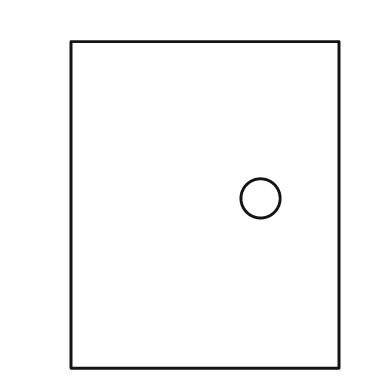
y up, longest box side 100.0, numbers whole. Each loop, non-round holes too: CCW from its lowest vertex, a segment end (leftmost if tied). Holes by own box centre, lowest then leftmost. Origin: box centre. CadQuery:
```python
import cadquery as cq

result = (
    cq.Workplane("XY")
    .moveTo(-41.0, -50.0)
    .lineTo(41.0, -50.0)
    .lineTo(41.0, 50.0)
    .lineTo(-41.0, 50.0)
    .close()
    .moveTo(17.0, 2.0)
    .circle(6.0)
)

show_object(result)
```